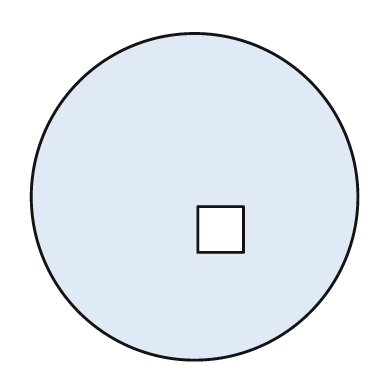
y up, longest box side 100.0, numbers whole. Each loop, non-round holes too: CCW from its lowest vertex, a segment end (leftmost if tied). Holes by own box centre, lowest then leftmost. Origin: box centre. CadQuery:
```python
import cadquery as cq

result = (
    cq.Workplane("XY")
    .moveTo(0.0, 0.0)
    .circle(50.0)
    .moveTo(1.0, -17.0)
    .lineTo(15.0, -17.0)
    .lineTo(15.0, -3.0)
    .lineTo(1.0, -3.0)
    .close()
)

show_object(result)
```